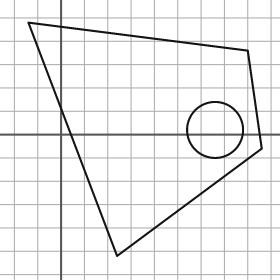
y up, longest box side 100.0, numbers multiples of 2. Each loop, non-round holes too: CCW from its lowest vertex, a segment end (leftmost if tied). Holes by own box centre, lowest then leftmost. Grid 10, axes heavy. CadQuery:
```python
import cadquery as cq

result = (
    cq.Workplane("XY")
    .moveTo(24.0, -52.0)
    .lineTo(86.0, -6.0)
    .lineTo(80.0, 36.0)
    .lineTo(-14.0, 48.0)
    .close()
    .moveTo(66.0, 2.0)
    .circle(12.0)
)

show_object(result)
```